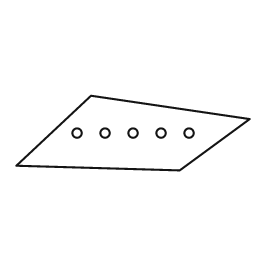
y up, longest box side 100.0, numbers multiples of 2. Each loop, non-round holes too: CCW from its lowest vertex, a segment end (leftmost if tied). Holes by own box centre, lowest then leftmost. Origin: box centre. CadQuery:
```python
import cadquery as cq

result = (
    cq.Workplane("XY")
    .moveTo(20.0, -16.0)
    .lineTo(50.0, 6.0)
    .lineTo(-18.0, 16.0)
    .lineTo(-50.0, -14.0)
    .close()
    .moveTo(-24.0, 0.0)
    .circle(2.0)
    .moveTo(-12.0, 0.0)
    .circle(2.0)
    .moveTo(0.0, 0.0)
    .circle(2.0)
    .moveTo(12.0, 0.0)
    .circle(2.0)
    .moveTo(24.0, 0.0)
    .circle(2.0)
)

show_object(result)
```